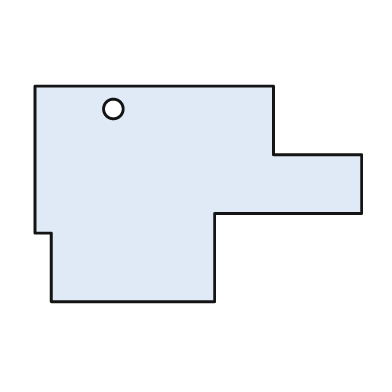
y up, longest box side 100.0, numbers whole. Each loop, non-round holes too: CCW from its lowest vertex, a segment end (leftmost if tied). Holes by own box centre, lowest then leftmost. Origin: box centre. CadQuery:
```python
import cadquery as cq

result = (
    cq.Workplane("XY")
    .moveTo(-45.0, -33.0)
    .lineTo(5.0, -33.0)
    .lineTo(5.0, -6.0)
    .lineTo(50.0, -6.0)
    .lineTo(50.0, 12.0)
    .lineTo(23.0, 12.0)
    .lineTo(23.0, 33.0)
    .lineTo(-50.0, 33.0)
    .lineTo(-50.0, -12.0)
    .lineTo(-45.0, -12.0)
    .close()
    .moveTo(-26.0, 26.0)
    .circle(3.0)
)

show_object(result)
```